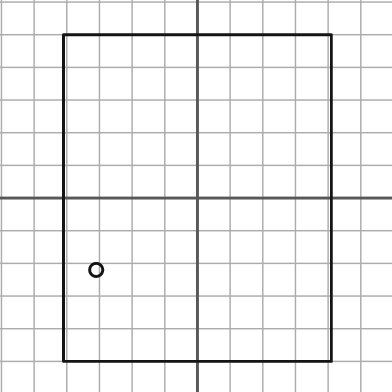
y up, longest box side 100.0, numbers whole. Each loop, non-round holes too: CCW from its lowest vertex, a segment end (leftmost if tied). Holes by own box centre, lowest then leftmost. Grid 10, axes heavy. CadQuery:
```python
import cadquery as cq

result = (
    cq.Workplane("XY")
    .moveTo(-41.0, -50.0)
    .lineTo(41.0, -50.0)
    .lineTo(41.0, 50.0)
    .lineTo(-41.0, 50.0)
    .close()
    .moveTo(-31.0, -22.0)
    .circle(2.0)
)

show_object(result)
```